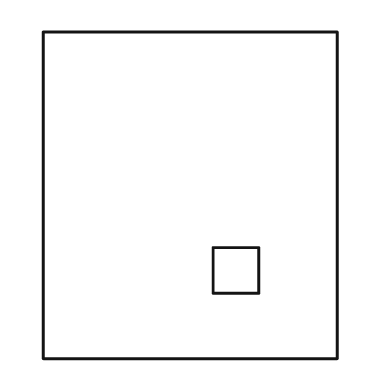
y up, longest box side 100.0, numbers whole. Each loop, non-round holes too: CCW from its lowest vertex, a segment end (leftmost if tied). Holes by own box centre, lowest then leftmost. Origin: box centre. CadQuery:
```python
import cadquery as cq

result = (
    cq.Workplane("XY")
    .moveTo(-45.0, -50.0)
    .lineTo(45.0, -50.0)
    .lineTo(45.0, 50.0)
    .lineTo(-45.0, 50.0)
    .close()
    .moveTo(7.0, -30.0)
    .lineTo(21.0, -30.0)
    .lineTo(21.0, -16.0)
    .lineTo(7.0, -16.0)
    .close()
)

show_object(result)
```